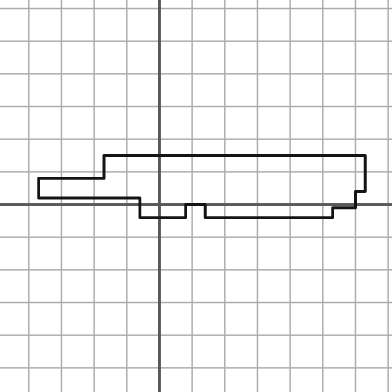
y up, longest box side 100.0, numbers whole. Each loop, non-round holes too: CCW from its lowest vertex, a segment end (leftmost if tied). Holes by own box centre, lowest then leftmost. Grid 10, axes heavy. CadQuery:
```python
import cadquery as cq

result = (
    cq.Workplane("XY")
    .moveTo(-6.0, -4.0)
    .lineTo(8.0, -4.0)
    .lineTo(8.0, 0.0)
    .lineTo(14.0, 0.0)
    .lineTo(14.0, -4.0)
    .lineTo(53.0, -4.0)
    .lineTo(53.0, -1.0)
    .lineTo(60.0, -1.0)
    .lineTo(60.0, 4.0)
    .lineTo(63.0, 4.0)
    .lineTo(63.0, 15.0)
    .lineTo(-17.0, 15.0)
    .lineTo(-17.0, 8.0)
    .lineTo(-37.0, 8.0)
    .lineTo(-37.0, 2.0)
    .lineTo(-6.0, 2.0)
    .close()
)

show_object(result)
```